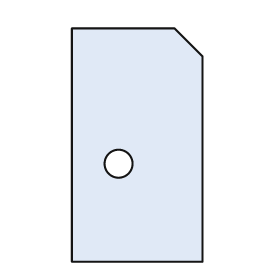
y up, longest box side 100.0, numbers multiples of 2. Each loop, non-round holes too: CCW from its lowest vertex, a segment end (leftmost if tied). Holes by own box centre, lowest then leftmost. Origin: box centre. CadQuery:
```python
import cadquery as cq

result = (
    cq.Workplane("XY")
    .moveTo(-28.0, -50.0)
    .lineTo(28.0, -50.0)
    .lineTo(28.0, 38.0)
    .lineTo(16.0, 50.0)
    .lineTo(-28.0, 50.0)
    .close()
    .moveTo(-8.0, -8.0)
    .circle(6.0)
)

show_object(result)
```